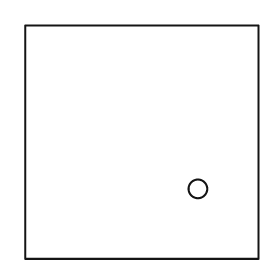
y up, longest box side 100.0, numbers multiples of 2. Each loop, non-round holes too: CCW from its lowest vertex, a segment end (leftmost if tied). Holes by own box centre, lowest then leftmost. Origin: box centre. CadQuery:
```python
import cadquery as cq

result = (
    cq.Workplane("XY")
    .moveTo(-50.0, -50.0)
    .lineTo(50.0, -50.0)
    .lineTo(50.0, 50.0)
    .lineTo(-50.0, 50.0)
    .close()
    .moveTo(24.0, -20.0)
    .circle(4.0)
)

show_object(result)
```